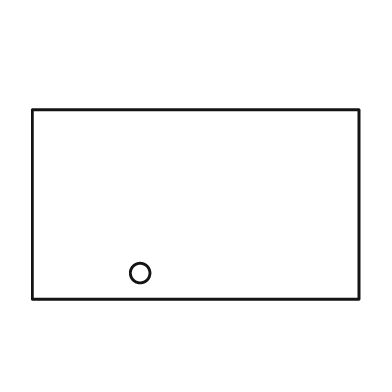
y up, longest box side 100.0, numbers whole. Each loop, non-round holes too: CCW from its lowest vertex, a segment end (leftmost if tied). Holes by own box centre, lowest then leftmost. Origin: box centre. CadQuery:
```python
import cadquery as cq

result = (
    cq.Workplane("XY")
    .moveTo(-50.0, -29.0)
    .lineTo(50.0, -29.0)
    .lineTo(50.0, 29.0)
    .lineTo(-50.0, 29.0)
    .close()
    .moveTo(-17.0, -21.0)
    .circle(3.0)
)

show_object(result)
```